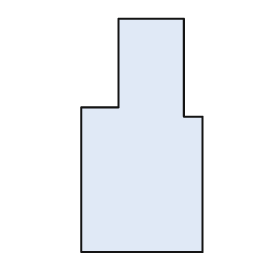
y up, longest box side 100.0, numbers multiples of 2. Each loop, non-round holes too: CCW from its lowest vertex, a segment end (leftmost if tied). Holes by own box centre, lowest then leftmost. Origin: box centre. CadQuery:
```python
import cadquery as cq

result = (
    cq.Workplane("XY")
    .moveTo(-26.0, -50.0)
    .lineTo(26.0, -50.0)
    .lineTo(26.0, 8.0)
    .lineTo(18.0, 8.0)
    .lineTo(18.0, 50.0)
    .lineTo(-10.0, 50.0)
    .lineTo(-10.0, 12.0)
    .lineTo(-26.0, 12.0)
    .close()
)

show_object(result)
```